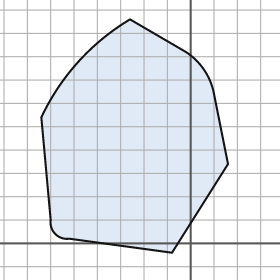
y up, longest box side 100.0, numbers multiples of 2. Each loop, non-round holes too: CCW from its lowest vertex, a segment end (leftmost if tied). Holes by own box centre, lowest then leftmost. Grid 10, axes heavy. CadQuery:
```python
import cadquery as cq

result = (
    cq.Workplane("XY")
    .moveTo(-8.0, -4.0)
    .lineTo(16.0, 34.0)
    .lineTo(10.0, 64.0)
    .threePointArc((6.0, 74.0), (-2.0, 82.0))
    .lineTo(-26.0, 96.0)
    .threePointArc((-48.0, 78.0), (-64.0, 54.0))
    .lineTo(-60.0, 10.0)
    .threePointArc((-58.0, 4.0), (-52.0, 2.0))
    .close()
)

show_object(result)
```